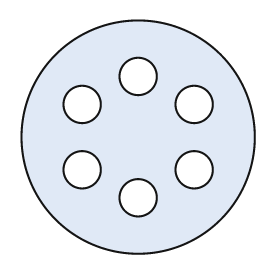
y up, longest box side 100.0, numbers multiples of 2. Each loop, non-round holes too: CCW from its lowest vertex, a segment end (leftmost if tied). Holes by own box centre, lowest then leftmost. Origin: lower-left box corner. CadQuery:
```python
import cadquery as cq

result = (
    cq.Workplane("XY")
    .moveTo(50.0, 50.0)
    .circle(50.0)
    .moveTo(50.0, 24.0)
    .circle(8.0)
    .moveTo(26.0, 36.0)
    .circle(8.0)
    .moveTo(74.0, 36.0)
    .circle(8.0)
    .moveTo(26.0, 64.0)
    .circle(8.0)
    .moveTo(74.0, 64.0)
    .circle(8.0)
    .moveTo(50.0, 76.0)
    .circle(8.0)
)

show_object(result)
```